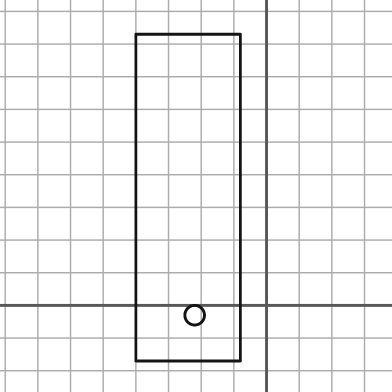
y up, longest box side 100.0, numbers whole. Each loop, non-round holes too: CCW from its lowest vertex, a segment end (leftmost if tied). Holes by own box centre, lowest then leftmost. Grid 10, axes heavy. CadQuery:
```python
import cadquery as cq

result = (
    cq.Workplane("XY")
    .moveTo(-40.0, -17.0)
    .lineTo(-8.0, -17.0)
    .lineTo(-8.0, 83.0)
    .lineTo(-40.0, 83.0)
    .close()
    .moveTo(-22.0, -3.0)
    .circle(3.0)
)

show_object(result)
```